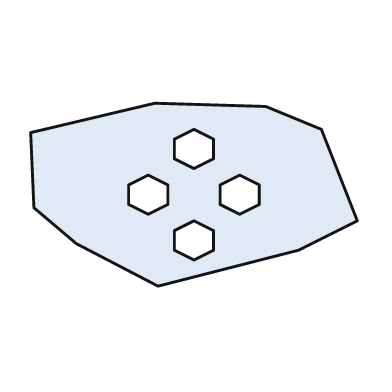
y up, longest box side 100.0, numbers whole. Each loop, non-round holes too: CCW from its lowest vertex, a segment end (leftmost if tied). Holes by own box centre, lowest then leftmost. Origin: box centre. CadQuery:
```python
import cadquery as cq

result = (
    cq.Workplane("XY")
    .moveTo(-11.0, -28.0)
    .lineTo(32.0, -17.0)
    .lineTo(50.0, -8.0)
    .lineTo(39.0, 20.0)
    .lineTo(22.0, 27.0)
    .lineTo(-12.0, 28.0)
    .lineTo(-50.0, 19.0)
    .lineTo(-49.0, -4.0)
    .lineTo(-36.0, -15.0)
    .close()
    .moveTo(0.0, -20.0)
    .lineTo(6.0, -17.0)
    .lineTo(6.0, -11.0)
    .lineTo(0.0, -8.0)
    .lineTo(-6.0, -11.0)
    .lineTo(-6.0, -17.0)
    .close()
    .moveTo(-14.0, -6.0)
    .lineTo(-8.0, -3.0)
    .lineTo(-8.0, 3.0)
    .lineTo(-14.0, 6.0)
    .lineTo(-20.0, 3.0)
    .lineTo(-20.0, -3.0)
    .close()
    .moveTo(14.0, -6.0)
    .lineTo(20.0, -3.0)
    .lineTo(20.0, 3.0)
    .lineTo(14.0, 6.0)
    .lineTo(8.0, 3.0)
    .lineTo(8.0, -3.0)
    .close()
    .moveTo(0.0, 8.0)
    .lineTo(6.0, 11.0)
    .lineTo(6.0, 17.0)
    .lineTo(0.0, 20.0)
    .lineTo(-6.0, 17.0)
    .lineTo(-6.0, 11.0)
    .close()
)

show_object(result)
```